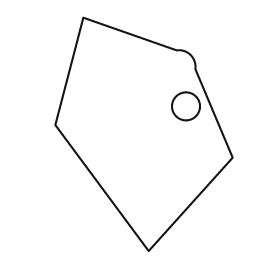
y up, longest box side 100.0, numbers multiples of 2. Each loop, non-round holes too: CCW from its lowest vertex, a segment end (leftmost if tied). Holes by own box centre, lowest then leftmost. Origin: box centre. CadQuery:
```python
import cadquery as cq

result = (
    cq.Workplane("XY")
    .moveTo(2.0, -50.0)
    .lineTo(38.0, -10.0)
    .lineTo(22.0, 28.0)
    .threePointArc((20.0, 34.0), (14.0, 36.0))
    .lineTo(-26.0, 50.0)
    .lineTo(-38.0, 4.0)
    .close()
    .moveTo(18.0, 12.0)
    .circle(6.0)
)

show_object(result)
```